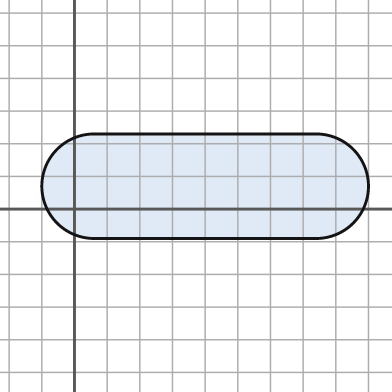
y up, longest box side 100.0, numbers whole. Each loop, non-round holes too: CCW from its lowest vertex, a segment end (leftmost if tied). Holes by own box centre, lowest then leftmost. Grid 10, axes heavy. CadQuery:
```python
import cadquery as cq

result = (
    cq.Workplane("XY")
    .moveTo(6.0, -9.0)
    .lineTo(74.0, -9.0)
    .threePointArc((90.0, 7.0), (74.0, 23.0))
    .lineTo(6.0, 23.0)
    .threePointArc((-10.0, 7.0), (6.0, -9.0))
    .close()
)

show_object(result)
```